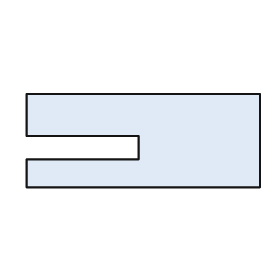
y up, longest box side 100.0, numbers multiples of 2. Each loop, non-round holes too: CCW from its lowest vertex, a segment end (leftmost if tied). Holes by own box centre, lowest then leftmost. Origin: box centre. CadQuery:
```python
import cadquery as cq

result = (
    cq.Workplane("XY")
    .moveTo(-50.0, -20.0)
    .lineTo(50.0, -20.0)
    .lineTo(50.0, 20.0)
    .lineTo(-50.0, 20.0)
    .lineTo(-50.0, 2.0)
    .lineTo(-2.0, 2.0)
    .lineTo(-2.0, -8.0)
    .lineTo(-50.0, -8.0)
    .close()
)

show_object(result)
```